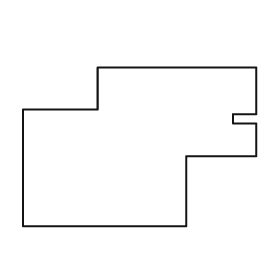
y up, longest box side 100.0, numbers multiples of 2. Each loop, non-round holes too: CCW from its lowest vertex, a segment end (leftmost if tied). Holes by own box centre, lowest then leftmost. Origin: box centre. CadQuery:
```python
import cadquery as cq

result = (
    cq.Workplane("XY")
    .moveTo(-50.0, -34.0)
    .lineTo(20.0, -34.0)
    .lineTo(20.0, -4.0)
    .lineTo(50.0, -4.0)
    .lineTo(50.0, 10.0)
    .lineTo(40.0, 10.0)
    .lineTo(40.0, 14.0)
    .lineTo(50.0, 14.0)
    .lineTo(50.0, 34.0)
    .lineTo(-18.0, 34.0)
    .lineTo(-18.0, 16.0)
    .lineTo(-50.0, 16.0)
    .close()
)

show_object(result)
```